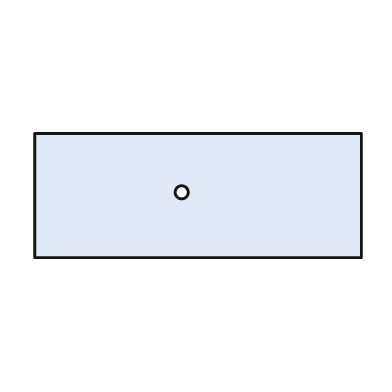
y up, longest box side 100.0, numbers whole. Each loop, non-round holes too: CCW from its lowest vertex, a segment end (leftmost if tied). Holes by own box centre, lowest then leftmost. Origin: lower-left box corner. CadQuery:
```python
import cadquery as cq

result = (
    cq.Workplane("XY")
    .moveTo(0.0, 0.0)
    .lineTo(100.0, 0.0)
    .lineTo(100.0, 38.0)
    .lineTo(0.0, 38.0)
    .close()
    .moveTo(45.0, 20.0)
    .circle(2.0)
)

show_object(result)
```